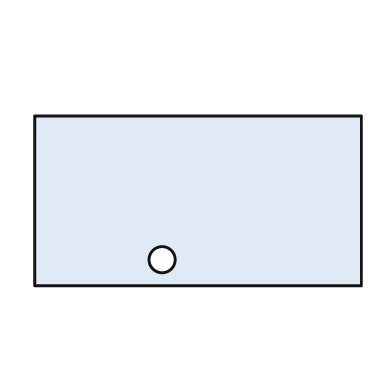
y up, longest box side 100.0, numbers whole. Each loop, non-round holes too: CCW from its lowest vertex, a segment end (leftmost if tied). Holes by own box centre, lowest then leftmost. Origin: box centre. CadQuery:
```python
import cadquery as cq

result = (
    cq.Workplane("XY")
    .moveTo(-50.0, -26.0)
    .lineTo(50.0, -26.0)
    .lineTo(50.0, 26.0)
    .lineTo(-50.0, 26.0)
    .close()
    .moveTo(-11.0, -18.0)
    .circle(4.0)
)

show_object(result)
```